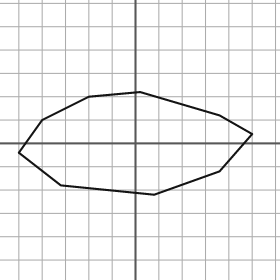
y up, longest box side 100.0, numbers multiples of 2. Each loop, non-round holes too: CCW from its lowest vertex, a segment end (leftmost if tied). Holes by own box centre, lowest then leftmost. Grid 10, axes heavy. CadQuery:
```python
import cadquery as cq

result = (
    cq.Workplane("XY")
    .moveTo(8.0, -22.0)
    .lineTo(36.0, -12.0)
    .lineTo(50.0, 4.0)
    .lineTo(36.0, 12.0)
    .lineTo(2.0, 22.0)
    .lineTo(-20.0, 20.0)
    .lineTo(-40.0, 10.0)
    .lineTo(-50.0, -4.0)
    .lineTo(-32.0, -18.0)
    .close()
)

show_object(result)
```